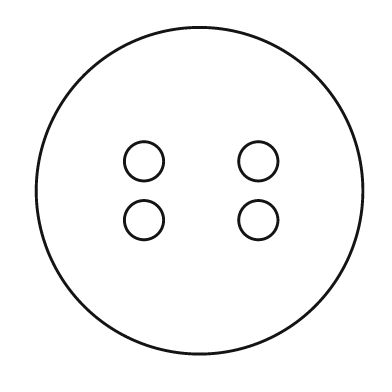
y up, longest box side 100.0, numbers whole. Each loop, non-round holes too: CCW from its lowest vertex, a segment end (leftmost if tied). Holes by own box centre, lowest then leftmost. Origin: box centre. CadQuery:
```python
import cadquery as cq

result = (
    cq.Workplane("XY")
    .moveTo(0.0, 0.0)
    .circle(50.0)
    .moveTo(-17.0, -9.0)
    .circle(6.0)
    .moveTo(18.0, -9.0)
    .circle(6.0)
    .moveTo(-17.0, 9.0)
    .circle(6.0)
    .moveTo(18.0, 9.0)
    .circle(6.0)
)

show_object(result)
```